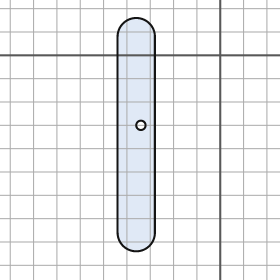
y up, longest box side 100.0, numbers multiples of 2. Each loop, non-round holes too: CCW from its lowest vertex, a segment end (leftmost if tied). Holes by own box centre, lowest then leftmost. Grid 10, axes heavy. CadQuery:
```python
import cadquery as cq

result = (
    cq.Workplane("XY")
    .moveTo(-44.0, -76.0)
    .threePointArc((-36.0, -84.0), (-28.0, -76.0))
    .lineTo(-28.0, 8.0)
    .threePointArc((-36.0, 16.0), (-44.0, 8.0))
    .close()
    .moveTo(-34.0, -30.0)
    .circle(2.0)
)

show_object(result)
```